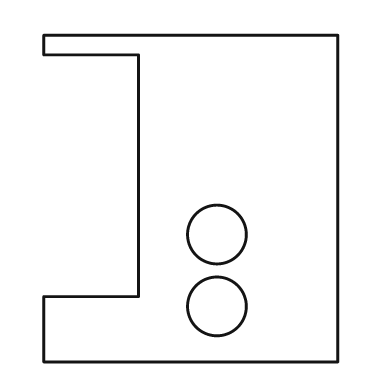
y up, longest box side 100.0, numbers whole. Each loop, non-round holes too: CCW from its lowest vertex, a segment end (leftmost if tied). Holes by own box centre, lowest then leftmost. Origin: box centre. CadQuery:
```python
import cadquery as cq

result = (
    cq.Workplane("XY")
    .moveTo(-45.0, -50.0)
    .lineTo(45.0, -50.0)
    .lineTo(45.0, 50.0)
    .lineTo(-45.0, 50.0)
    .lineTo(-45.0, 44.0)
    .lineTo(-16.0, 44.0)
    .lineTo(-16.0, -30.0)
    .lineTo(-45.0, -30.0)
    .close()
    .moveTo(8.0, -33.0)
    .circle(9.0)
    .moveTo(8.0, -11.0)
    .circle(9.0)
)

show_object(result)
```